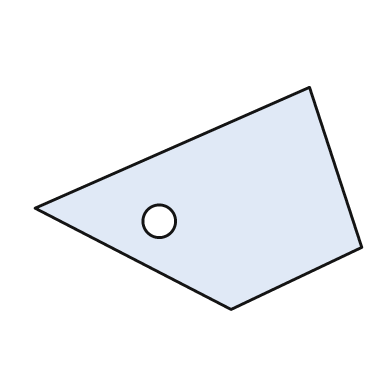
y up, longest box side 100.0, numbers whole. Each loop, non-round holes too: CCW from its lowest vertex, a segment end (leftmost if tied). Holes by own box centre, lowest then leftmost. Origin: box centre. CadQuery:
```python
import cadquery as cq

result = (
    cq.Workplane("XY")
    .moveTo(10.0, -34.0)
    .lineTo(50.0, -15.0)
    .lineTo(34.0, 34.0)
    .lineTo(-50.0, -3.0)
    .close()
    .moveTo(-12.0, -7.0)
    .circle(5.0)
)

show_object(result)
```